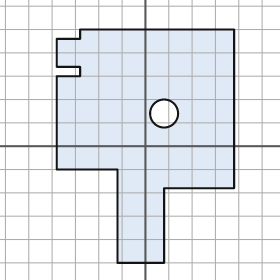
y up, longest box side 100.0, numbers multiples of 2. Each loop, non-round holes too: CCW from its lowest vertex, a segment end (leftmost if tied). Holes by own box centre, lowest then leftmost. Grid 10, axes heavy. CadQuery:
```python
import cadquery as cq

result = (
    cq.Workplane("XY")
    .moveTo(-12.0, -50.0)
    .lineTo(8.0, -50.0)
    .lineTo(8.0, -18.0)
    .lineTo(38.0, -18.0)
    .lineTo(38.0, 50.0)
    .lineTo(-28.0, 50.0)
    .lineTo(-28.0, 46.0)
    .lineTo(-38.0, 46.0)
    .lineTo(-38.0, 34.0)
    .lineTo(-28.0, 34.0)
    .lineTo(-28.0, 30.0)
    .lineTo(-38.0, 30.0)
    .lineTo(-38.0, -10.0)
    .lineTo(-12.0, -10.0)
    .close()
    .moveTo(8.0, 14.0)
    .circle(6.0)
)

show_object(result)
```